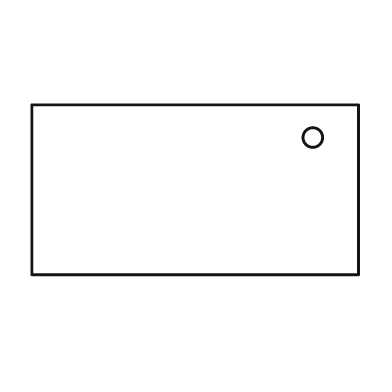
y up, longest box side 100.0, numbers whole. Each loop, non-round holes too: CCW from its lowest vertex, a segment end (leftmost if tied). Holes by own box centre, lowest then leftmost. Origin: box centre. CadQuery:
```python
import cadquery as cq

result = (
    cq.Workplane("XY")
    .moveTo(-50.0, -26.0)
    .lineTo(50.0, -26.0)
    .lineTo(50.0, 26.0)
    .lineTo(-50.0, 26.0)
    .close()
    .moveTo(36.0, 16.0)
    .circle(3.0)
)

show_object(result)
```